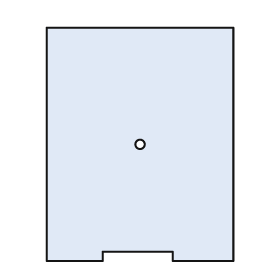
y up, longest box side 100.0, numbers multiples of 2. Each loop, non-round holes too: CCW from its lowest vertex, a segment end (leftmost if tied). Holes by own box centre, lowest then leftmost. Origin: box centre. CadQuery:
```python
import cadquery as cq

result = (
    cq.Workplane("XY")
    .moveTo(-40.0, -50.0)
    .lineTo(-16.0, -50.0)
    .lineTo(-16.0, -46.0)
    .lineTo(14.0, -46.0)
    .lineTo(14.0, -50.0)
    .lineTo(40.0, -50.0)
    .lineTo(40.0, 50.0)
    .lineTo(-40.0, 50.0)
    .close()
    .moveTo(0.0, 0.0)
    .circle(2.0)
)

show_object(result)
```